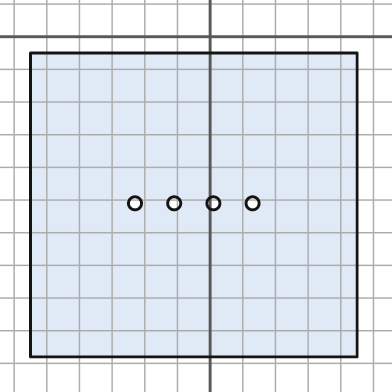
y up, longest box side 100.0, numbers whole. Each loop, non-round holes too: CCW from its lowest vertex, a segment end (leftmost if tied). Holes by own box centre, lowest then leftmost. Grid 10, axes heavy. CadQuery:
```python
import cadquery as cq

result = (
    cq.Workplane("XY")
    .moveTo(-55.0, -98.0)
    .lineTo(45.0, -98.0)
    .lineTo(45.0, -5.0)
    .lineTo(-55.0, -5.0)
    .close()
    .moveTo(-23.0, -51.0)
    .circle(2.0)
    .moveTo(-11.0, -51.0)
    .circle(2.0)
    .moveTo(1.0, -51.0)
    .circle(2.0)
    .moveTo(13.0, -51.0)
    .circle(2.0)
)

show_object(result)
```